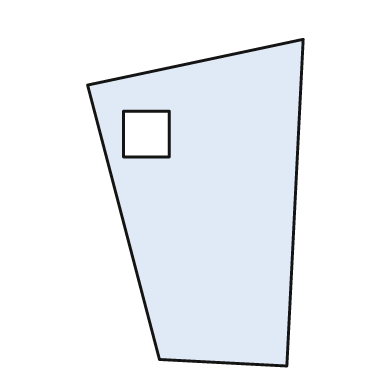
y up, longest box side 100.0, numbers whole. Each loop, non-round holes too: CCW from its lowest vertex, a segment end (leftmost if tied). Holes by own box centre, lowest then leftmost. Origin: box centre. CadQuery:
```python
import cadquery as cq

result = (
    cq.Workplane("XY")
    .moveTo(28.0, -50.0)
    .lineTo(33.0, 50.0)
    .lineTo(-33.0, 36.0)
    .lineTo(-11.0, -48.0)
    .close()
    .moveTo(-22.0, 14.0)
    .lineTo(-8.0, 14.0)
    .lineTo(-8.0, 28.0)
    .lineTo(-22.0, 28.0)
    .close()
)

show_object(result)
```